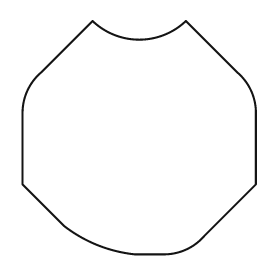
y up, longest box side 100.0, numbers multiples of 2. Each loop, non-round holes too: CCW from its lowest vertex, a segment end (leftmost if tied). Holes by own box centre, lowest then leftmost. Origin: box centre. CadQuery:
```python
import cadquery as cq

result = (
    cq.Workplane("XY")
    .moveTo(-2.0, -50.0)
    .lineTo(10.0, -50.0)
    .threePointArc((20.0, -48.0), (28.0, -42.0))
    .lineTo(50.0, -20.0)
    .lineTo(50.0, 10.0)
    .threePointArc((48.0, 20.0), (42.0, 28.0))
    .lineTo(20.0, 50.0)
    .threePointArc((0.0, 42.0), (-20.0, 50.0))
    .lineTo(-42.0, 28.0)
    .threePointArc((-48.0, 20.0), (-50.0, 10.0))
    .lineTo(-50.0, -20.0)
    .lineTo(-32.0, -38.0)
    .threePointArc((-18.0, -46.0), (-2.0, -50.0))
    .close()
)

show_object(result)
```